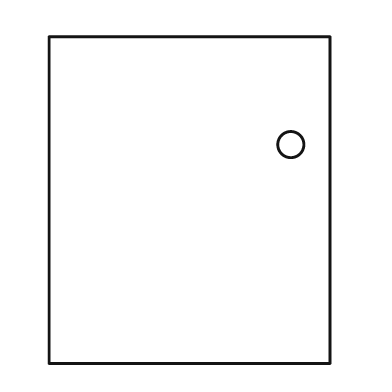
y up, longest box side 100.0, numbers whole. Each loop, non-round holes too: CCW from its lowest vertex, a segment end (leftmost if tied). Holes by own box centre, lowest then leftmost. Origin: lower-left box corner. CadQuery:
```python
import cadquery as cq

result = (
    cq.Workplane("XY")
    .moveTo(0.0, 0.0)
    .lineTo(86.0, 0.0)
    .lineTo(86.0, 100.0)
    .lineTo(0.0, 100.0)
    .close()
    .moveTo(74.0, 67.0)
    .circle(4.0)
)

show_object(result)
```